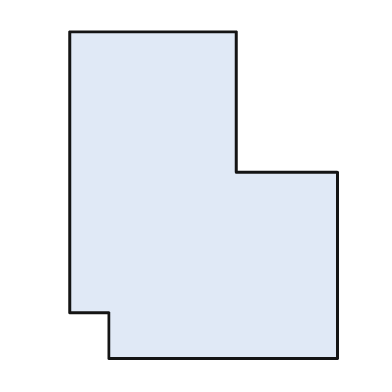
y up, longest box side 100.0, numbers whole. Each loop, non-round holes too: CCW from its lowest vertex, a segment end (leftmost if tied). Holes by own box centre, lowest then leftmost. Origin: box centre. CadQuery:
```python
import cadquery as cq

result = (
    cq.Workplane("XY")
    .moveTo(-29.0, -50.0)
    .lineTo(41.0, -50.0)
    .lineTo(41.0, 7.0)
    .lineTo(10.0, 7.0)
    .lineTo(10.0, 50.0)
    .lineTo(-41.0, 50.0)
    .lineTo(-41.0, -36.0)
    .lineTo(-29.0, -36.0)
    .close()
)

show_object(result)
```